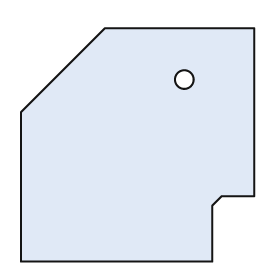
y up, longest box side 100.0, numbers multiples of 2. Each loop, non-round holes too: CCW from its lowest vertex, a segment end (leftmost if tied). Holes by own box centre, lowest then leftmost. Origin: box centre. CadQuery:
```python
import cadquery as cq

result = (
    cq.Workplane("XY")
    .moveTo(-50.0, -50.0)
    .lineTo(32.0, -50.0)
    .lineTo(32.0, -26.0)
    .lineTo(36.0, -22.0)
    .lineTo(50.0, -22.0)
    .lineTo(50.0, 50.0)
    .lineTo(-14.0, 50.0)
    .lineTo(-50.0, 14.0)
    .close()
    .moveTo(20.0, 28.0)
    .circle(4.0)
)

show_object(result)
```